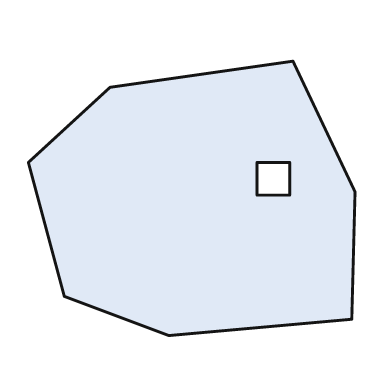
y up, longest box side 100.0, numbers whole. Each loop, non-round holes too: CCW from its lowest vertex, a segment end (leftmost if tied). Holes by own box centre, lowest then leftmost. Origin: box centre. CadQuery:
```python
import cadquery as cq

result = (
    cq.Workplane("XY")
    .moveTo(-7.0, -42.0)
    .lineTo(49.0, -37.0)
    .lineTo(50.0, 2.0)
    .lineTo(31.0, 42.0)
    .lineTo(-25.0, 34.0)
    .lineTo(-50.0, 11.0)
    .lineTo(-39.0, -30.0)
    .close()
    .moveTo(20.0, 1.0)
    .lineTo(30.0, 1.0)
    .lineTo(30.0, 11.0)
    .lineTo(20.0, 11.0)
    .close()
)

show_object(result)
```